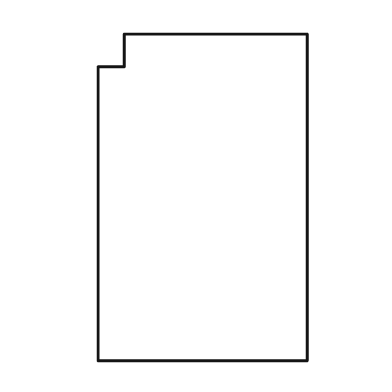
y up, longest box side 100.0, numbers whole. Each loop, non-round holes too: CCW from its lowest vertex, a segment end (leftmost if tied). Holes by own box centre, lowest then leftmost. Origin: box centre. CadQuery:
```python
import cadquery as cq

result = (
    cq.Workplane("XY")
    .moveTo(-32.0, -50.0)
    .lineTo(32.0, -50.0)
    .lineTo(32.0, 50.0)
    .lineTo(-24.0, 50.0)
    .lineTo(-24.0, 40.0)
    .lineTo(-32.0, 40.0)
    .close()
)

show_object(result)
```